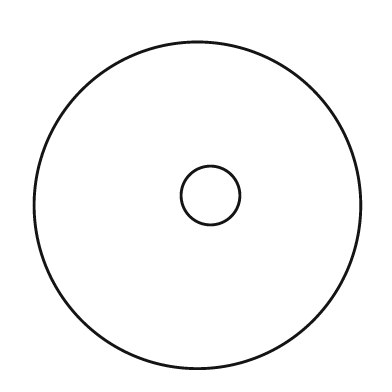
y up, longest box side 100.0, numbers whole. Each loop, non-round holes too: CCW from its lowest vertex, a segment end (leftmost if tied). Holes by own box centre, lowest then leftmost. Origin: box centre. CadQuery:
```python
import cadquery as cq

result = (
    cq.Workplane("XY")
    .moveTo(0.0, 0.0)
    .circle(50.0)
    .moveTo(4.0, 3.0)
    .circle(9.0)
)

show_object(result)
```